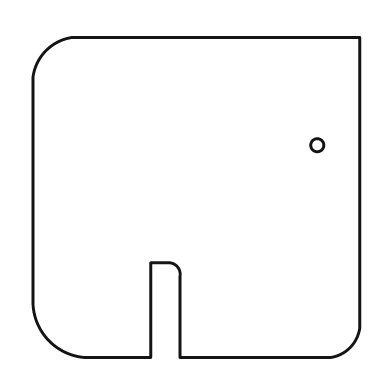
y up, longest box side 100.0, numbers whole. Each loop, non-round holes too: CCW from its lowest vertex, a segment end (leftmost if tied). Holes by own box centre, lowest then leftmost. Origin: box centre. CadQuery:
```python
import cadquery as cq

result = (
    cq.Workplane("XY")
    .moveTo(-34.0, -49.0)
    .lineTo(-14.0, -49.0)
    .lineTo(-14.0, -20.0)
    .lineTo(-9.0, -20.0)
    .threePointArc((-6.0, -21.0), (-5.0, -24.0))
    .lineTo(-5.0, -49.0)
    .lineTo(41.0, -49.0)
    .threePointArc((47.0, -46.0), (50.0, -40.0))
    .lineTo(50.0, 49.0)
    .lineTo(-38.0, 49.0)
    .threePointArc((-46.0, 45.0), (-50.0, 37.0))
    .lineTo(-50.0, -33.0)
    .threePointArc((-45.0, -44.0), (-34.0, -49.0))
    .close()
    .moveTo(37.0, 16.0)
    .circle(2.0)
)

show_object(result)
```